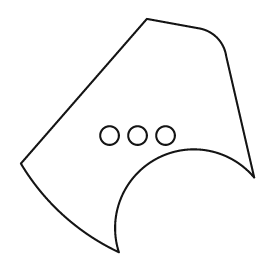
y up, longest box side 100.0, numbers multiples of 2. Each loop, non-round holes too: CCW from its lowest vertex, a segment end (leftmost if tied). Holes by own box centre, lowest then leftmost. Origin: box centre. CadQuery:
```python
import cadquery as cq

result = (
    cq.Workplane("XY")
    .moveTo(-8.0, -50.0)
    .threePointArc((8.0, -10.0), (50.0, -18.0))
    .lineTo(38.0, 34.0)
    .threePointArc((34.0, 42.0), (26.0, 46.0))
    .lineTo(4.0, 50.0)
    .lineTo(-50.0, -12.0)
    .threePointArc((-32.0, -34.0), (-8.0, -50.0))
    .close()
    .moveTo(-12.0, 0.0)
    .circle(4.0)
    .moveTo(0.0, 0.0)
    .circle(4.0)
    .moveTo(12.0, 0.0)
    .circle(4.0)
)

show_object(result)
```